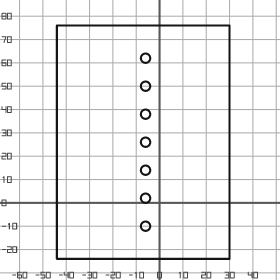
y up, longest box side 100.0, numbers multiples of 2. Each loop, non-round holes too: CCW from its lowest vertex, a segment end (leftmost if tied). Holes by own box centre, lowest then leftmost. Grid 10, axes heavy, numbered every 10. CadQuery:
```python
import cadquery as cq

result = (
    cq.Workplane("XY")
    .moveTo(-44.0, -24.0)
    .lineTo(30.0, -24.0)
    .lineTo(30.0, 76.0)
    .lineTo(-44.0, 76.0)
    .close()
    .moveTo(-6.0, -10.0)
    .circle(2.0)
    .moveTo(-6.0, 2.0)
    .circle(2.0)
    .moveTo(-6.0, 14.0)
    .circle(2.0)
    .moveTo(-6.0, 26.0)
    .circle(2.0)
    .moveTo(-6.0, 38.0)
    .circle(2.0)
    .moveTo(-6.0, 50.0)
    .circle(2.0)
    .moveTo(-6.0, 62.0)
    .circle(2.0)
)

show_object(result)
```